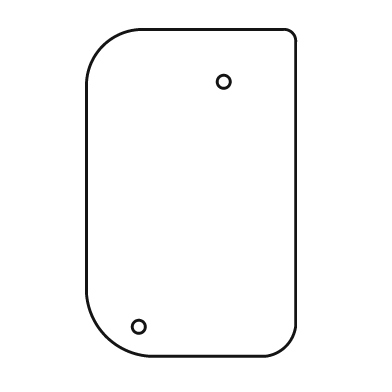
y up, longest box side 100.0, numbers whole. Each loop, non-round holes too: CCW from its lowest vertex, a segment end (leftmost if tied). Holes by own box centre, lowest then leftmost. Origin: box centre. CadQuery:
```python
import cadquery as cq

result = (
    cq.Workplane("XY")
    .moveTo(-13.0, -50.0)
    .lineTo(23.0, -50.0)
    .threePointArc((29.0, -47.0), (32.0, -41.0))
    .lineTo(32.0, 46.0)
    .threePointArc((31.0, 49.0), (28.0, 50.0))
    .lineTo(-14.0, 50.0)
    .threePointArc((-27.0, 45.0), (-32.0, 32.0))
    .lineTo(-32.0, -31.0)
    .threePointArc((-26.0, -44.0), (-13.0, -50.0))
    .close()
    .moveTo(-16.0, -41.0)
    .circle(2.0)
    .moveTo(10.0, 34.0)
    .circle(2.0)
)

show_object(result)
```